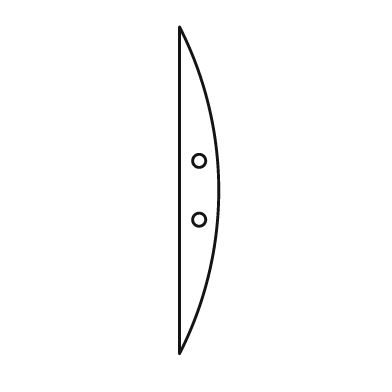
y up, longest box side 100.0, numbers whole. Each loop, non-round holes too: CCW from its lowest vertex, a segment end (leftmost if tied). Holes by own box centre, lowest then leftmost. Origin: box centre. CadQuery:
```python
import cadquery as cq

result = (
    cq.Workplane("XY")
    .moveTo(-6.0, -50.0)
    .threePointArc((6.0, 0.0), (-6.0, 50.0))
    .close()
    .moveTo(0.0, -9.0)
    .circle(2.0)
    .moveTo(0.0, 9.0)
    .circle(2.0)
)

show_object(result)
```